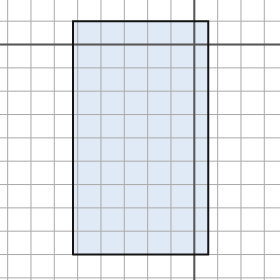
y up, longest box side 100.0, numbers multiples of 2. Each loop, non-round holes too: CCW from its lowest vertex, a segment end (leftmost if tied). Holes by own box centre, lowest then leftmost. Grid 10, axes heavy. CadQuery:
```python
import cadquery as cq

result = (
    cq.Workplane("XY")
    .moveTo(-52.0, -90.0)
    .lineTo(6.0, -90.0)
    .lineTo(6.0, 10.0)
    .lineTo(-52.0, 10.0)
    .close()
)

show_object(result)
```